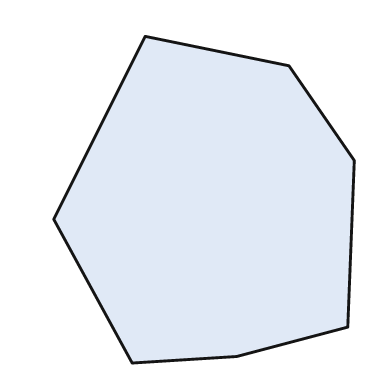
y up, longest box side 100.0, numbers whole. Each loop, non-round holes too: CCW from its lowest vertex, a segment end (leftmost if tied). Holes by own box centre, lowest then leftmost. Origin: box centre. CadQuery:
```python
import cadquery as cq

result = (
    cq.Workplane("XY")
    .moveTo(-22.0, -50.0)
    .lineTo(10.0, -48.0)
    .lineTo(44.0, -39.0)
    .lineTo(46.0, 12.0)
    .lineTo(26.0, 41.0)
    .lineTo(-18.0, 50.0)
    .lineTo(-46.0, -6.0)
    .close()
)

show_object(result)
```